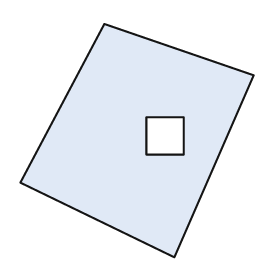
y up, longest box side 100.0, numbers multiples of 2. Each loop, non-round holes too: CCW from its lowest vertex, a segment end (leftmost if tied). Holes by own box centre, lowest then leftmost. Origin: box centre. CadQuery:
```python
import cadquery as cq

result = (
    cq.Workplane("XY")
    .moveTo(16.0, -50.0)
    .lineTo(50.0, 28.0)
    .lineTo(-14.0, 50.0)
    .lineTo(-50.0, -18.0)
    .close()
    .moveTo(4.0, -6.0)
    .lineTo(20.0, -6.0)
    .lineTo(20.0, 10.0)
    .lineTo(4.0, 10.0)
    .close()
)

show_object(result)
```